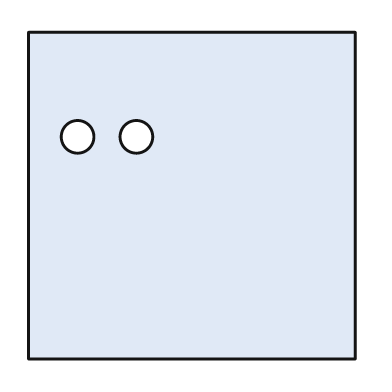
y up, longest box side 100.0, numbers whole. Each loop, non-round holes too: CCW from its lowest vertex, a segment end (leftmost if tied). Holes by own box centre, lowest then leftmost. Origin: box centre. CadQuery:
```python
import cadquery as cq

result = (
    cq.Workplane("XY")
    .moveTo(-50.0, -50.0)
    .lineTo(50.0, -50.0)
    .lineTo(50.0, 50.0)
    .lineTo(-50.0, 50.0)
    .close()
    .moveTo(-35.0, 18.0)
    .circle(5.0)
    .moveTo(-17.0, 18.0)
    .circle(5.0)
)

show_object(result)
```